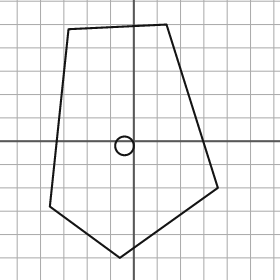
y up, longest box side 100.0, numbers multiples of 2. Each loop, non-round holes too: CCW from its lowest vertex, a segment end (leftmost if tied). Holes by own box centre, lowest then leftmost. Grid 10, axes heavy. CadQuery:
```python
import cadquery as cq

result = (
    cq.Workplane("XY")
    .moveTo(-6.0, -50.0)
    .lineTo(36.0, -20.0)
    .lineTo(14.0, 50.0)
    .lineTo(-28.0, 48.0)
    .lineTo(-36.0, -28.0)
    .close()
    .moveTo(-4.0, -2.0)
    .circle(4.0)
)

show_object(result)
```